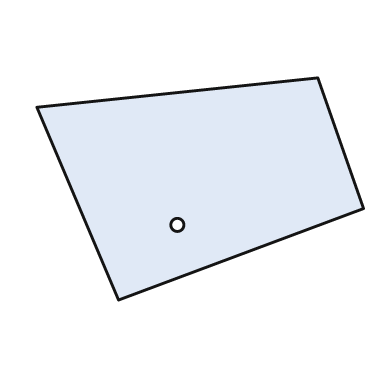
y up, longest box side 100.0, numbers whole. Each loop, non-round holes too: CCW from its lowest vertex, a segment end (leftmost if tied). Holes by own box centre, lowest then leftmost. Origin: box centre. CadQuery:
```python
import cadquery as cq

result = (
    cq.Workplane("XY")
    .moveTo(-25.0, -34.0)
    .lineTo(50.0, -6.0)
    .lineTo(36.0, 34.0)
    .lineTo(-50.0, 25.0)
    .close()
    .moveTo(-7.0, -11.0)
    .circle(2.0)
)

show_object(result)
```